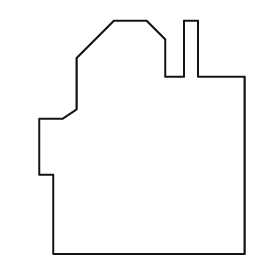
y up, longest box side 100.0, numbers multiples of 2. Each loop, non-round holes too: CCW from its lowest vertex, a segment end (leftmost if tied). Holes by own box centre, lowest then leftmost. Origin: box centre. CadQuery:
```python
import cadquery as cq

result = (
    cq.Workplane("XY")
    .moveTo(-38.0, -50.0)
    .lineTo(44.0, -50.0)
    .lineTo(44.0, 26.0)
    .lineTo(24.0, 26.0)
    .lineTo(24.0, 50.0)
    .lineTo(18.0, 50.0)
    .lineTo(18.0, 26.0)
    .lineTo(10.0, 26.0)
    .lineTo(10.0, 42.0)
    .lineTo(2.0, 50.0)
    .lineTo(-12.0, 50.0)
    .lineTo(-28.0, 34.0)
    .lineTo(-28.0, 12.0)
    .lineTo(-34.0, 8.0)
    .lineTo(-44.0, 8.0)
    .lineTo(-44.0, -16.0)
    .lineTo(-38.0, -16.0)
    .close()
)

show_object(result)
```